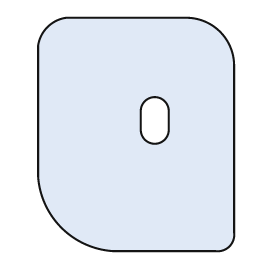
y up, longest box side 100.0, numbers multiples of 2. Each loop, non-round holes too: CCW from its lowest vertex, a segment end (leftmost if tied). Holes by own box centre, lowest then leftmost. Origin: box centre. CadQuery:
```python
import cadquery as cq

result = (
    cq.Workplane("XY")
    .moveTo(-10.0, -50.0)
    .lineTo(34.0, -50.0)
    .threePointArc((40.0, -48.0), (42.0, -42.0))
    .lineTo(42.0, 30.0)
    .threePointArc((36.0, 44.0), (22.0, 50.0))
    .lineTo(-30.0, 50.0)
    .threePointArc((-38.0, 46.0), (-42.0, 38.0))
    .lineTo(-42.0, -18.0)
    .threePointArc((-32.0, -40.0), (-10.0, -50.0))
    .close()
    .moveTo(2.0, 2.0)
    .threePointArc((8.0, -4.0), (14.0, 2.0))
    .lineTo(14.0, 10.0)
    .threePointArc((8.0, 16.0), (2.0, 10.0))
    .close()
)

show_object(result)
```